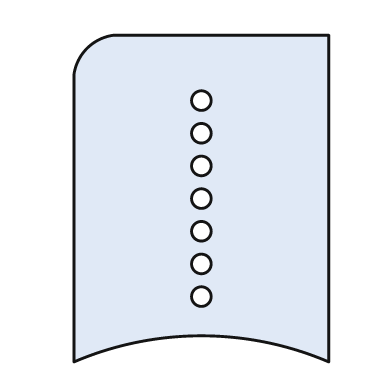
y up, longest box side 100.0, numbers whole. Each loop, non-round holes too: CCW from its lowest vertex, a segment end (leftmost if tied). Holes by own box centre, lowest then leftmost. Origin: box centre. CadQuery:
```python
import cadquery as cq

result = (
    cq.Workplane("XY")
    .moveTo(-39.0, -50.0)
    .threePointArc((0.0, -42.0), (39.0, -50.0))
    .lineTo(39.0, 50.0)
    .lineTo(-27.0, 50.0)
    .threePointArc((-35.0, 46.0), (-39.0, 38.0))
    .close()
    .moveTo(0.0, -30.0)
    .circle(3.0)
    .moveTo(0.0, -20.0)
    .circle(3.0)
    .moveTo(0.0, -10.0)
    .circle(3.0)
    .moveTo(0.0, 0.0)
    .circle(3.0)
    .moveTo(0.0, 10.0)
    .circle(3.0)
    .moveTo(0.0, 20.0)
    .circle(3.0)
    .moveTo(0.0, 30.0)
    .circle(3.0)
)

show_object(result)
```